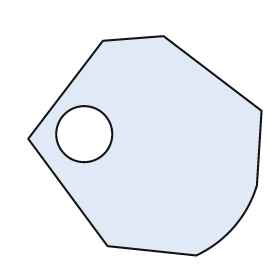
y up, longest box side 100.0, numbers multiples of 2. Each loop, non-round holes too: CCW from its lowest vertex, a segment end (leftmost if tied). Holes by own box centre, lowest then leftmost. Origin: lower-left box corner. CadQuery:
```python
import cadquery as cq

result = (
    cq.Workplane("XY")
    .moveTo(72.0, 0.0)
    .threePointArc((88.0, 12.0), (98.0, 30.0))
    .lineTo(100.0, 62.0)
    .lineTo(58.0, 94.0)
    .lineTo(32.0, 92.0)
    .lineTo(0.0, 50.0)
    .lineTo(34.0, 4.0)
    .close()
    .moveTo(24.0, 52.0)
    .circle(12.0)
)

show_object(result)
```